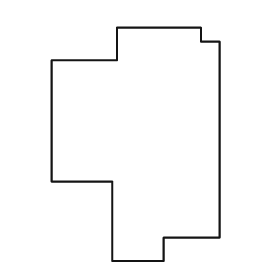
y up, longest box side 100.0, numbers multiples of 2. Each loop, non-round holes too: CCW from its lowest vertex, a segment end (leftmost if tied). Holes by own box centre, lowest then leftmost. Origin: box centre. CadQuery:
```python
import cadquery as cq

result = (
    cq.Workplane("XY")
    .moveTo(-10.0, -50.0)
    .lineTo(12.0, -50.0)
    .lineTo(12.0, -40.0)
    .lineTo(36.0, -40.0)
    .lineTo(36.0, 44.0)
    .lineTo(28.0, 44.0)
    .lineTo(28.0, 50.0)
    .lineTo(-8.0, 50.0)
    .lineTo(-8.0, 36.0)
    .lineTo(-36.0, 36.0)
    .lineTo(-36.0, -16.0)
    .lineTo(-10.0, -16.0)
    .close()
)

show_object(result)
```